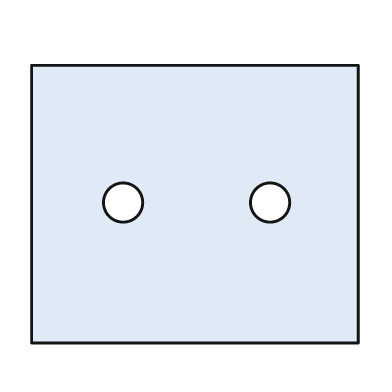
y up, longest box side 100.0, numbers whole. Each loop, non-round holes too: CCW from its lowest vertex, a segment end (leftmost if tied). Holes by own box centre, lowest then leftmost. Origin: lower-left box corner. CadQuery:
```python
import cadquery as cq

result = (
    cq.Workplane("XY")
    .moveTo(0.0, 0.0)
    .lineTo(100.0, 0.0)
    .lineTo(100.0, 85.0)
    .lineTo(0.0, 85.0)
    .close()
    .moveTo(28.0, 43.0)
    .circle(6.0)
    .moveTo(73.0, 43.0)
    .circle(6.0)
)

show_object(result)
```